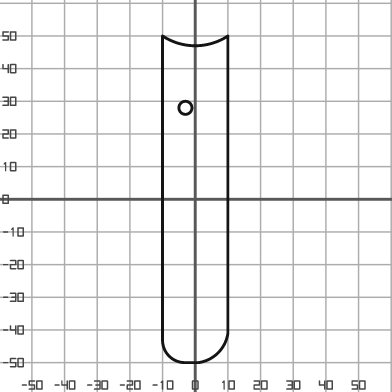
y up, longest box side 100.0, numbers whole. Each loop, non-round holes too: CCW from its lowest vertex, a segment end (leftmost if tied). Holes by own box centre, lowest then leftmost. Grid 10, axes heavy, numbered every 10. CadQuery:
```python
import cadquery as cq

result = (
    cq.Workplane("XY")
    .moveTo(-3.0, -50.0)
    .lineTo(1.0, -50.0)
    .threePointArc((7.0, -47.0), (10.0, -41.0))
    .lineTo(10.0, 50.0)
    .threePointArc((0.0, 47.0), (-10.0, 50.0))
    .lineTo(-10.0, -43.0)
    .threePointArc((-8.0, -48.0), (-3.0, -50.0))
    .close()
    .moveTo(-3.0, 28.0)
    .circle(2.0)
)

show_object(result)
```